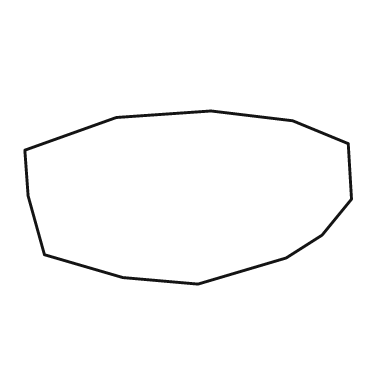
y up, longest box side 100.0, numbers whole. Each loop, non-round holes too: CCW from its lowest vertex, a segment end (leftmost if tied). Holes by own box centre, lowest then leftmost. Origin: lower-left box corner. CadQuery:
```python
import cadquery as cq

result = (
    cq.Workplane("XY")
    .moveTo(53.0, 0.0)
    .lineTo(80.0, 8.0)
    .lineTo(91.0, 15.0)
    .lineTo(100.0, 26.0)
    .lineTo(99.0, 43.0)
    .lineTo(82.0, 50.0)
    .lineTo(57.0, 53.0)
    .lineTo(28.0, 51.0)
    .lineTo(0.0, 41.0)
    .lineTo(1.0, 27.0)
    .lineTo(6.0, 9.0)
    .lineTo(30.0, 2.0)
    .close()
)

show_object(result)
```